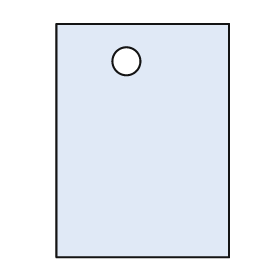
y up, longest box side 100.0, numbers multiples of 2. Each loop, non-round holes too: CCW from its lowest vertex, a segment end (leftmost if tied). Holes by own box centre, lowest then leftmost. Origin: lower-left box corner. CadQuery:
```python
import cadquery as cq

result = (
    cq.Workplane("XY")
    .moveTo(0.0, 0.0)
    .lineTo(74.0, 0.0)
    .lineTo(74.0, 100.0)
    .lineTo(0.0, 100.0)
    .close()
    .moveTo(30.0, 84.0)
    .circle(6.0)
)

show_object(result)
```